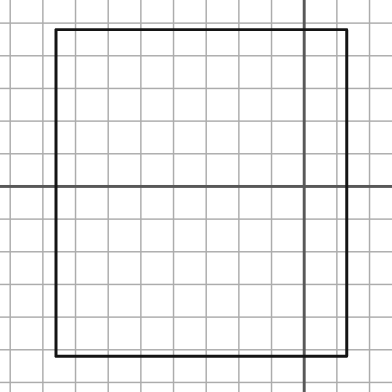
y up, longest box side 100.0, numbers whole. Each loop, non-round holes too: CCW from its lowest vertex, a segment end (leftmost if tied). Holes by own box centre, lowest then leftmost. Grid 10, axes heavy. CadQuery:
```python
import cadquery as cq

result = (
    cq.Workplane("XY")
    .moveTo(-76.0, -52.0)
    .lineTo(13.0, -52.0)
    .lineTo(13.0, 48.0)
    .lineTo(-76.0, 48.0)
    .close()
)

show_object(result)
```